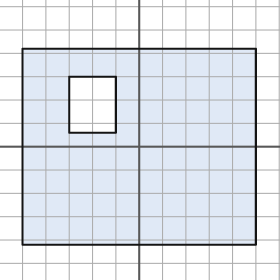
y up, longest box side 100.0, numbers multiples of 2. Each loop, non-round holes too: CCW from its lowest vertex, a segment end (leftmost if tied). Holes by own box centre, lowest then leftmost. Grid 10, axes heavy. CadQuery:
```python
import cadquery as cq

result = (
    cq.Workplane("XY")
    .moveTo(-50.0, -42.0)
    .lineTo(50.0, -42.0)
    .lineTo(50.0, 42.0)
    .lineTo(-50.0, 42.0)
    .close()
    .moveTo(-30.0, 6.0)
    .lineTo(-10.0, 6.0)
    .lineTo(-10.0, 30.0)
    .lineTo(-30.0, 30.0)
    .close()
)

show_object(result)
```